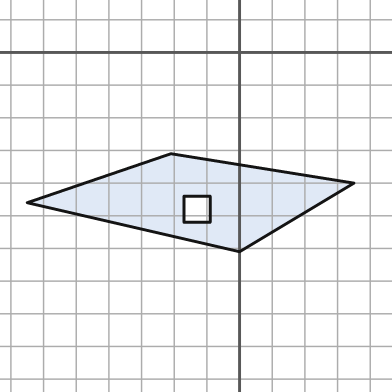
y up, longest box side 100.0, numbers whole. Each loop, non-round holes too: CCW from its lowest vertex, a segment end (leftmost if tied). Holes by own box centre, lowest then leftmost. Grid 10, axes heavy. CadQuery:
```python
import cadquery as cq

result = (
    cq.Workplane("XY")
    .moveTo(0.0, -61.0)
    .lineTo(35.0, -40.0)
    .lineTo(-21.0, -31.0)
    .lineTo(-65.0, -46.0)
    .close()
    .moveTo(-17.0, -52.0)
    .lineTo(-9.0, -52.0)
    .lineTo(-9.0, -44.0)
    .lineTo(-17.0, -44.0)
    .close()
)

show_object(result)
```